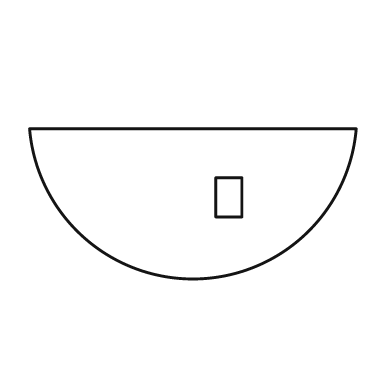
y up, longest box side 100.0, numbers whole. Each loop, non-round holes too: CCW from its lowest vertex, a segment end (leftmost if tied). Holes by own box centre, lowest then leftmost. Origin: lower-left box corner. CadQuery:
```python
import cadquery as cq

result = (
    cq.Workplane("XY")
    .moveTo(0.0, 46.0)
    .threePointArc((50.0, 0.0), (100.0, 46.0))
    .close()
    .moveTo(57.0, 19.0)
    .lineTo(65.0, 19.0)
    .lineTo(65.0, 31.0)
    .lineTo(57.0, 31.0)
    .close()
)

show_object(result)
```